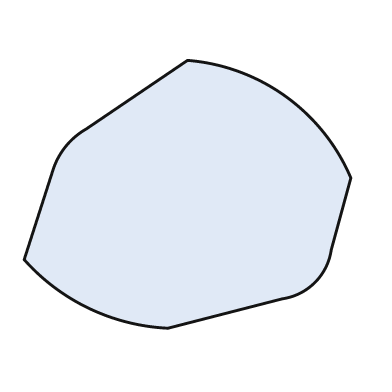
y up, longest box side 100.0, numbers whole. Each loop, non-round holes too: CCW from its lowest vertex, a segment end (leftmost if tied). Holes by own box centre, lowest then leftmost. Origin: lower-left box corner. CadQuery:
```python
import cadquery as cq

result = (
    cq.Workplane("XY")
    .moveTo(44.0, 0.0)
    .lineTo(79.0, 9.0)
    .threePointArc((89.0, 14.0), (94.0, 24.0))
    .lineTo(100.0, 46.0)
    .threePointArc((80.0, 71.0), (50.0, 82.0))
    .lineTo(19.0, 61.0)
    .threePointArc((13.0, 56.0), (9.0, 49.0))
    .lineTo(0.0, 21.0)
    .threePointArc((20.0, 6.0), (44.0, 0.0))
    .close()
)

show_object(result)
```